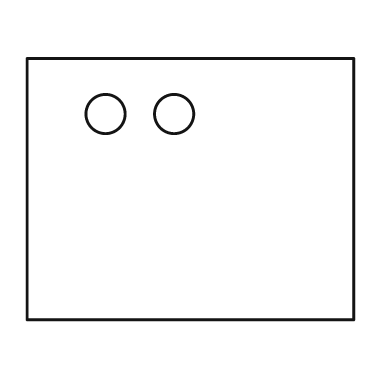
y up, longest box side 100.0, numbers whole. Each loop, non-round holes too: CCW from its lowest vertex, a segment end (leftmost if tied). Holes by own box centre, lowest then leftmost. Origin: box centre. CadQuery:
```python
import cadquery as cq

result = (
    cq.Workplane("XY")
    .moveTo(-50.0, -40.0)
    .lineTo(50.0, -40.0)
    .lineTo(50.0, 40.0)
    .lineTo(-50.0, 40.0)
    .close()
    .moveTo(-26.0, 23.0)
    .circle(6.0)
    .moveTo(-5.0, 23.0)
    .circle(6.0)
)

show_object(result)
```